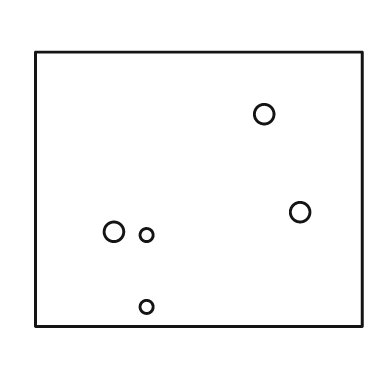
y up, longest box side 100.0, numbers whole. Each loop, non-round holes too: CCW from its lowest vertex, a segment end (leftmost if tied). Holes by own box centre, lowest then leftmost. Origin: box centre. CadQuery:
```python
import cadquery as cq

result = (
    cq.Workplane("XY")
    .moveTo(-50.0, -42.0)
    .lineTo(50.0, -42.0)
    .lineTo(50.0, 42.0)
    .lineTo(-50.0, 42.0)
    .close()
    .moveTo(-16.0, -36.0)
    .circle(2.0)
    .moveTo(-16.0, -14.0)
    .circle(2.0)
    .moveTo(-26.0, -13.0)
    .circle(3.0)
    .moveTo(31.0, -7.0)
    .circle(3.0)
    .moveTo(20.0, 23.0)
    .circle(3.0)
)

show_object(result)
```